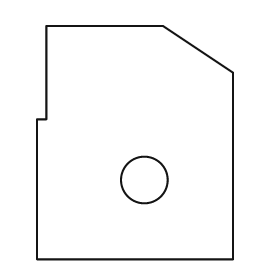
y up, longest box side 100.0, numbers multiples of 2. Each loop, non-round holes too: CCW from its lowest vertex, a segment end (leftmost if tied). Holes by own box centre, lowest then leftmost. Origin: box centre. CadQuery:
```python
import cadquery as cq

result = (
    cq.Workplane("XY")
    .moveTo(-42.0, -50.0)
    .lineTo(42.0, -50.0)
    .lineTo(42.0, 30.0)
    .lineTo(12.0, 50.0)
    .lineTo(-38.0, 50.0)
    .lineTo(-38.0, 10.0)
    .lineTo(-42.0, 10.0)
    .close()
    .moveTo(4.0, -16.0)
    .circle(10.0)
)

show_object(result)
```